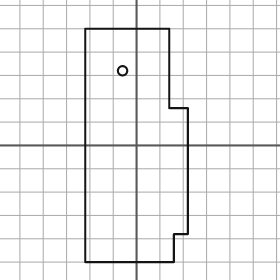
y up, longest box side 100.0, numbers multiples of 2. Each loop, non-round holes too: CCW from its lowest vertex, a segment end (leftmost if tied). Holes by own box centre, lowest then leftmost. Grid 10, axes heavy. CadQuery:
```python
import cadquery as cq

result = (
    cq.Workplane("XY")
    .moveTo(-22.0, -50.0)
    .lineTo(16.0, -50.0)
    .lineTo(16.0, -38.0)
    .lineTo(22.0, -38.0)
    .lineTo(22.0, 16.0)
    .lineTo(14.0, 16.0)
    .lineTo(14.0, 50.0)
    .lineTo(-22.0, 50.0)
    .close()
    .moveTo(-6.0, 32.0)
    .circle(2.0)
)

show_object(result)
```